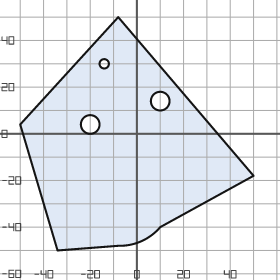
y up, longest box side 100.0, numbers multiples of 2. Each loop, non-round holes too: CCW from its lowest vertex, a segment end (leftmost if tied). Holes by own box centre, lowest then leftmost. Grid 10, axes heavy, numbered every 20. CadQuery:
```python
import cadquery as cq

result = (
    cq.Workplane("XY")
    .moveTo(-34.0, -50.0)
    .lineTo(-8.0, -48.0)
    .threePointArc((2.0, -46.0), (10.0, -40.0))
    .lineTo(50.0, -18.0)
    .lineTo(-8.0, 50.0)
    .lineTo(-50.0, 4.0)
    .close()
    .moveTo(-20.0, 4.0)
    .circle(4.0)
    .moveTo(10.0, 14.0)
    .circle(4.0)
    .moveTo(-14.0, 30.0)
    .circle(2.0)
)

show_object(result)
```